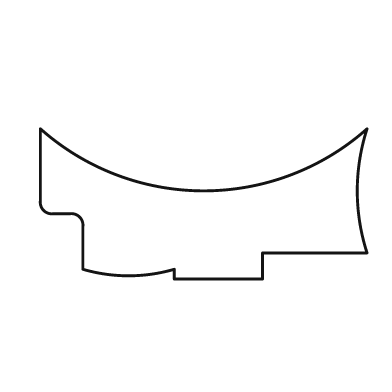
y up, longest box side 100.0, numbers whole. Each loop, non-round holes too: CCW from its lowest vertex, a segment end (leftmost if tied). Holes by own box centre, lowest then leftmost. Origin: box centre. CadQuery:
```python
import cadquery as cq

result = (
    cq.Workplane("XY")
    .moveTo(-9.0, -23.0)
    .lineTo(18.0, -23.0)
    .lineTo(18.0, -15.0)
    .lineTo(50.0, -15.0)
    .threePointArc((47.0, 4.0), (50.0, 23.0))
    .threePointArc((0.0, 4.0), (-50.0, 23.0))
    .lineTo(-50.0, 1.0)
    .threePointArc((-49.0, -2.0), (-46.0, -3.0))
    .lineTo(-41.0, -3.0)
    .threePointArc((-38.0, -4.0), (-37.0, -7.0))
    .lineTo(-37.0, -20.0)
    .threePointArc((-23.0, -22.0), (-9.0, -20.0))
    .close()
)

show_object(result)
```